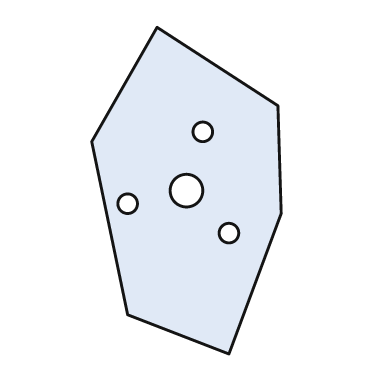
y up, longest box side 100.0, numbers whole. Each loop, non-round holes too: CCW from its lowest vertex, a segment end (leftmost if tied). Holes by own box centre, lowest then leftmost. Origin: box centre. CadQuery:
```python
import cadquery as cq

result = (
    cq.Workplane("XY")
    .moveTo(13.0, -50.0)
    .lineTo(29.0, -7.0)
    .lineTo(28.0, 26.0)
    .lineTo(-9.0, 50.0)
    .lineTo(-29.0, 15.0)
    .lineTo(-18.0, -38.0)
    .close()
    .moveTo(13.0, -13.0)
    .circle(3.0)
    .moveTo(-18.0, -4.0)
    .circle(3.0)
    .moveTo(0.0, 0.0)
    .circle(5.0)
    .moveTo(5.0, 18.0)
    .circle(3.0)
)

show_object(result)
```